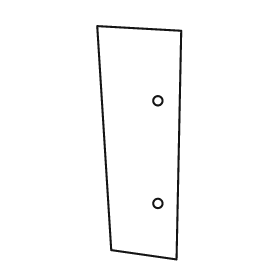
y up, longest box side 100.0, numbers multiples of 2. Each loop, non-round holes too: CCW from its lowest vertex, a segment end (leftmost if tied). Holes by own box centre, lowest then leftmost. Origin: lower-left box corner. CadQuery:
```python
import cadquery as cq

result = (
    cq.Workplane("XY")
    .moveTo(34.0, 0.0)
    .lineTo(36.0, 98.0)
    .lineTo(0.0, 100.0)
    .lineTo(6.0, 4.0)
    .close()
    .moveTo(26.0, 24.0)
    .circle(2.0)
    .moveTo(26.0, 68.0)
    .circle(2.0)
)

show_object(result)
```